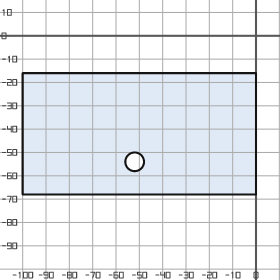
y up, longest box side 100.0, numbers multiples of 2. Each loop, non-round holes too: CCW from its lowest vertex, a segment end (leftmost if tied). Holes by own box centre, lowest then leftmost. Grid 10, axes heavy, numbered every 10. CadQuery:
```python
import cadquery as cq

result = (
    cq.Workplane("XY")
    .moveTo(-100.0, -68.0)
    .lineTo(0.0, -68.0)
    .lineTo(0.0, -16.0)
    .lineTo(-100.0, -16.0)
    .close()
    .moveTo(-52.0, -54.0)
    .circle(4.0)
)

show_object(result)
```